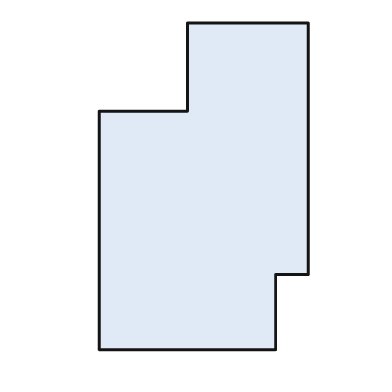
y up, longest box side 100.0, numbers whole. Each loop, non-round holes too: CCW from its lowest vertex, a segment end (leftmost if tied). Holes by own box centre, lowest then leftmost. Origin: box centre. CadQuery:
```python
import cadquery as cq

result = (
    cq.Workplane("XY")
    .moveTo(-32.0, -50.0)
    .lineTo(22.0, -50.0)
    .lineTo(22.0, -27.0)
    .lineTo(32.0, -27.0)
    .lineTo(32.0, 50.0)
    .lineTo(-5.0, 50.0)
    .lineTo(-5.0, 23.0)
    .lineTo(-32.0, 23.0)
    .close()
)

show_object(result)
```